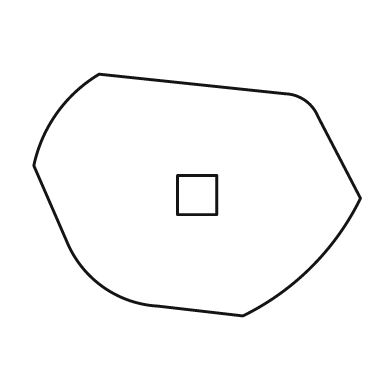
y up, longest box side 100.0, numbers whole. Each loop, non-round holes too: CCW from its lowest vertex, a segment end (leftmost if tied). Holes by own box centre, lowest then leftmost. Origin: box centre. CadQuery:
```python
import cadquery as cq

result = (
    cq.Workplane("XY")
    .moveTo(14.0, -37.0)
    .threePointArc((35.0, -22.0), (50.0, -1.0))
    .lineTo(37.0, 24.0)
    .threePointArc((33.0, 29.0), (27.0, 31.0))
    .lineTo(-30.0, 37.0)
    .threePointArc((-43.0, 25.0), (-50.0, 9.0))
    .lineTo(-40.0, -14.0)
    .threePointArc((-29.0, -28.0), (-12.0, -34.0))
    .close()
    .moveTo(-6.0, -6.0)
    .lineTo(6.0, -6.0)
    .lineTo(6.0, 6.0)
    .lineTo(-6.0, 6.0)
    .close()
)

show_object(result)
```